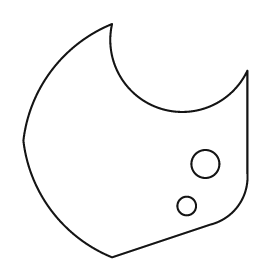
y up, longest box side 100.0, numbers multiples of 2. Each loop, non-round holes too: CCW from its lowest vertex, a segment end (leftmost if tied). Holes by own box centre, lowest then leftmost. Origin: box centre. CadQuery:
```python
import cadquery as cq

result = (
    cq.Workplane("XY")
    .moveTo(-10.0, -50.0)
    .lineTo(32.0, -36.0)
    .threePointArc((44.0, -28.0), (48.0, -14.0))
    .lineTo(48.0, 30.0)
    .threePointArc((10.0, 14.0), (-10.0, 50.0))
    .threePointArc((-36.0, 30.0), (-48.0, 0.0))
    .threePointArc((-36.0, -30.0), (-10.0, -50.0))
    .close()
    .moveTo(22.0, -28.0)
    .circle(4.0)
    .moveTo(30.0, -10.0)
    .circle(6.0)
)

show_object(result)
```